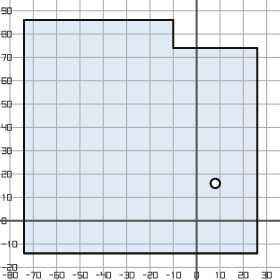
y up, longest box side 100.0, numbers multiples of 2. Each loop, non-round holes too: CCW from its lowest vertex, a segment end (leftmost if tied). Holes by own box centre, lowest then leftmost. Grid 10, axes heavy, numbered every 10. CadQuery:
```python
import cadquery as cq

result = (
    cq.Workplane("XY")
    .moveTo(-74.0, -14.0)
    .lineTo(26.0, -14.0)
    .lineTo(26.0, 74.0)
    .lineTo(-10.0, 74.0)
    .lineTo(-10.0, 86.0)
    .lineTo(-74.0, 86.0)
    .close()
    .moveTo(8.0, 16.0)
    .circle(2.0)
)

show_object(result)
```